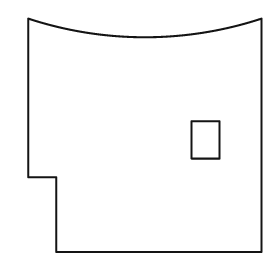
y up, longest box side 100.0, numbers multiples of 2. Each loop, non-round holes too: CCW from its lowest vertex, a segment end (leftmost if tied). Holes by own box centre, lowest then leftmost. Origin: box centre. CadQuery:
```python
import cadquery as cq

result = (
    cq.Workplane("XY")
    .moveTo(-38.0, -50.0)
    .lineTo(50.0, -50.0)
    .lineTo(50.0, 50.0)
    .threePointArc((0.0, 42.0), (-50.0, 50.0))
    .lineTo(-50.0, -18.0)
    .lineTo(-38.0, -18.0)
    .close()
    .moveTo(20.0, -10.0)
    .lineTo(32.0, -10.0)
    .lineTo(32.0, 6.0)
    .lineTo(20.0, 6.0)
    .close()
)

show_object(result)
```